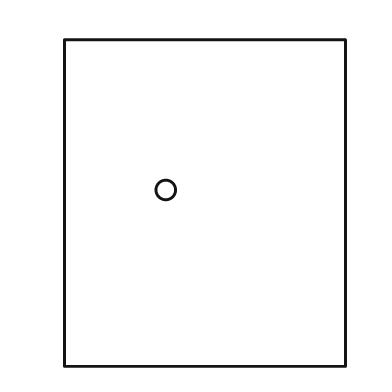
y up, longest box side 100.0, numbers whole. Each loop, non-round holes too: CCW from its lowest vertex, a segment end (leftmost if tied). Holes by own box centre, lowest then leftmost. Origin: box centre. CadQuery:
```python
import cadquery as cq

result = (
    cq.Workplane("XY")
    .moveTo(-43.0, -50.0)
    .lineTo(43.0, -50.0)
    .lineTo(43.0, 50.0)
    .lineTo(-43.0, 50.0)
    .close()
    .moveTo(-12.0, 4.0)
    .circle(3.0)
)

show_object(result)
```